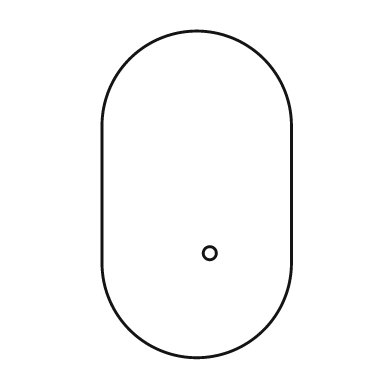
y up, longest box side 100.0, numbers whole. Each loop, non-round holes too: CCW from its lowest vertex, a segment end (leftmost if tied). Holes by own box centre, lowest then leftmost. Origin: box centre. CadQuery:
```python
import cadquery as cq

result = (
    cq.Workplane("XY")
    .moveTo(-29.0, -21.0)
    .threePointArc((0.0, -50.0), (29.0, -21.0))
    .lineTo(29.0, 21.0)
    .threePointArc((0.0, 50.0), (-29.0, 21.0))
    .close()
    .moveTo(4.0, -18.0)
    .circle(2.0)
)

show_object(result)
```